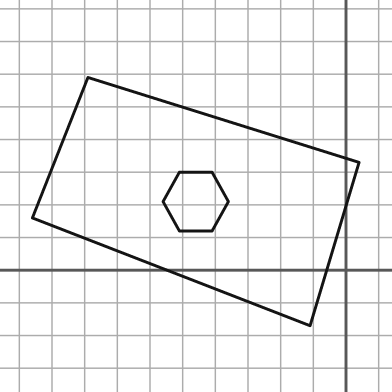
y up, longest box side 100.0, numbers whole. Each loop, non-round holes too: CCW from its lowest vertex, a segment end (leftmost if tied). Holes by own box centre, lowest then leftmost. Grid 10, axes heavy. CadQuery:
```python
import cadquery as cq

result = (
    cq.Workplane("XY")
    .moveTo(-11.0, -17.0)
    .lineTo(4.0, 33.0)
    .lineTo(-79.0, 59.0)
    .lineTo(-96.0, 16.0)
    .close()
    .moveTo(-51.0, 12.0)
    .lineTo(-41.0, 12.0)
    .lineTo(-36.0, 21.0)
    .lineTo(-41.0, 30.0)
    .lineTo(-51.0, 30.0)
    .lineTo(-56.0, 21.0)
    .close()
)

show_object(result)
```